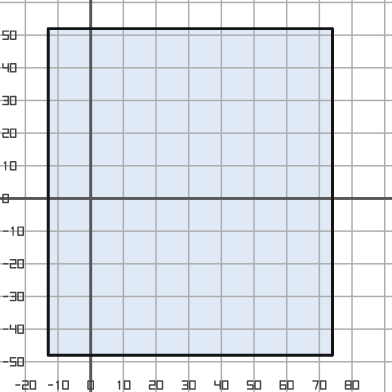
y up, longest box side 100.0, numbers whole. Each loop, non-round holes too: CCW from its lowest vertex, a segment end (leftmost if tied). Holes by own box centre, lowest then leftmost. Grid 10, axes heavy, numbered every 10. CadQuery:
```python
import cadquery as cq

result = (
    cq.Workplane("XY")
    .moveTo(-13.0, -48.0)
    .lineTo(74.0, -48.0)
    .lineTo(74.0, 52.0)
    .lineTo(-13.0, 52.0)
    .close()
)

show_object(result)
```